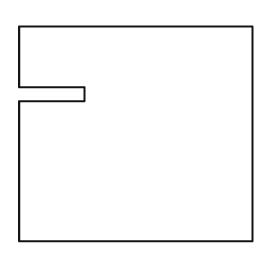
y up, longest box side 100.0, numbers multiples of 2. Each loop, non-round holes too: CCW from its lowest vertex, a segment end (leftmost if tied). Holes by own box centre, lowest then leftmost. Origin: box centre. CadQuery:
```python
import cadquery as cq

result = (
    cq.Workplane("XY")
    .moveTo(-50.0, -46.0)
    .lineTo(50.0, -46.0)
    .lineTo(50.0, 46.0)
    .lineTo(-50.0, 46.0)
    .lineTo(-50.0, 20.0)
    .lineTo(-22.0, 20.0)
    .lineTo(-22.0, 14.0)
    .lineTo(-50.0, 14.0)
    .close()
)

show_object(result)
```